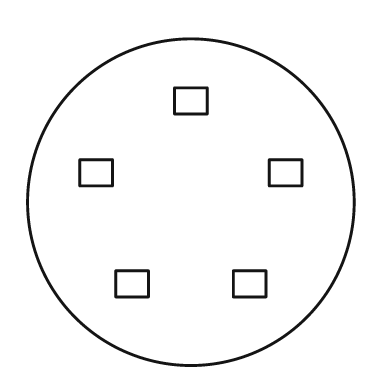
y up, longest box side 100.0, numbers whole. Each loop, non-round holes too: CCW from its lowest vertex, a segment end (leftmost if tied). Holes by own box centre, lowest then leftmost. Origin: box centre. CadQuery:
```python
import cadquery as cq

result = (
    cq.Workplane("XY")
    .moveTo(0.0, 0.0)
    .circle(50.0)
    .moveTo(-23.0, -29.0)
    .lineTo(-13.0, -29.0)
    .lineTo(-13.0, -21.0)
    .lineTo(-23.0, -21.0)
    .close()
    .moveTo(13.0, -29.0)
    .lineTo(23.0, -29.0)
    .lineTo(23.0, -21.0)
    .lineTo(13.0, -21.0)
    .close()
    .moveTo(-34.0, 5.0)
    .lineTo(-24.0, 5.0)
    .lineTo(-24.0, 13.0)
    .lineTo(-34.0, 13.0)
    .close()
    .moveTo(24.0, 5.0)
    .lineTo(34.0, 5.0)
    .lineTo(34.0, 13.0)
    .lineTo(24.0, 13.0)
    .close()
    .moveTo(-5.0, 27.0)
    .lineTo(5.0, 27.0)
    .lineTo(5.0, 35.0)
    .lineTo(-5.0, 35.0)
    .close()
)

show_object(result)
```